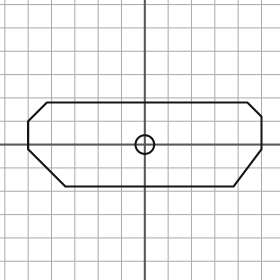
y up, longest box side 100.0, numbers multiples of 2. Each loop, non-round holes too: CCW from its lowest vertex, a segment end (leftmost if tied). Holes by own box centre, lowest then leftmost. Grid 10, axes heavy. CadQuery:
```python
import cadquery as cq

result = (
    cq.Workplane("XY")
    .moveTo(-34.0, -18.0)
    .lineTo(38.0, -18.0)
    .lineTo(50.0, -2.0)
    .lineTo(50.0, 12.0)
    .lineTo(44.0, 18.0)
    .lineTo(-42.0, 18.0)
    .lineTo(-50.0, 10.0)
    .lineTo(-50.0, -2.0)
    .close()
    .moveTo(0.0, 0.0)
    .circle(4.0)
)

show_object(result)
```